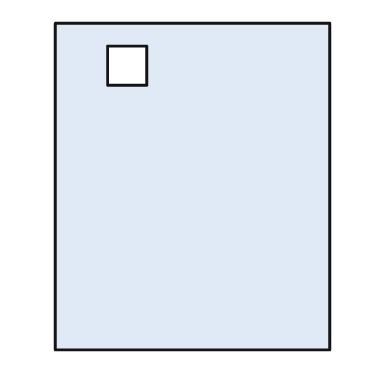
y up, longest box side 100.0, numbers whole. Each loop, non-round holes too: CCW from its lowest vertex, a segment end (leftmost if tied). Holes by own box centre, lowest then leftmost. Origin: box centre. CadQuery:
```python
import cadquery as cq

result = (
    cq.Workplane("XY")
    .moveTo(-42.0, -50.0)
    .lineTo(42.0, -50.0)
    .lineTo(42.0, 50.0)
    .lineTo(-42.0, 50.0)
    .close()
    .moveTo(-26.0, 31.0)
    .lineTo(-14.0, 31.0)
    .lineTo(-14.0, 43.0)
    .lineTo(-26.0, 43.0)
    .close()
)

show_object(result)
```